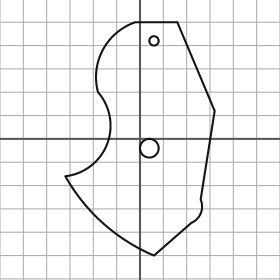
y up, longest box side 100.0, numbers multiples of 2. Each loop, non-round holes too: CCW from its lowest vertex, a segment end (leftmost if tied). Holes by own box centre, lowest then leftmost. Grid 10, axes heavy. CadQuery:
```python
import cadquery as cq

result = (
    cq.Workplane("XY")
    .moveTo(6.0, -50.0)
    .lineTo(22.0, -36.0)
    .threePointArc((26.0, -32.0), (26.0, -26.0))
    .lineTo(32.0, 12.0)
    .lineTo(16.0, 50.0)
    .lineTo(-2.0, 50.0)
    .threePointArc((-16.0, 38.0), (-18.0, 20.0))
    .threePointArc((-14.0, -2.0), (-32.0, -16.0))
    .threePointArc((-16.0, -36.0), (6.0, -50.0))
    .close()
    .moveTo(4.0, -4.0)
    .circle(4.0)
    .moveTo(6.0, 42.0)
    .circle(2.0)
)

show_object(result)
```